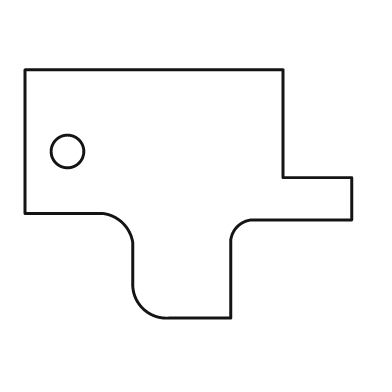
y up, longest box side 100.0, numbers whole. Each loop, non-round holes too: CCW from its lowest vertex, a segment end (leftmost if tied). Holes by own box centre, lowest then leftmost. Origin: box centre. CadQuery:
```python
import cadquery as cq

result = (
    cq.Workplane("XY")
    .moveTo(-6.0, -38.0)
    .lineTo(13.0, -38.0)
    .lineTo(13.0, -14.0)
    .threePointArc((15.0, -10.0), (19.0, -8.0))
    .lineTo(50.0, -8.0)
    .lineTo(50.0, 5.0)
    .lineTo(29.0, 5.0)
    .lineTo(29.0, 38.0)
    .lineTo(-50.0, 38.0)
    .lineTo(-50.0, -6.0)
    .lineTo(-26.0, -6.0)
    .threePointArc((-20.0, -9.0), (-17.0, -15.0))
    .lineTo(-17.0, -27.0)
    .threePointArc((-14.0, -35.0), (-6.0, -38.0))
    .close()
    .moveTo(-37.0, 13.0)
    .circle(5.0)
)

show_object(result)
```